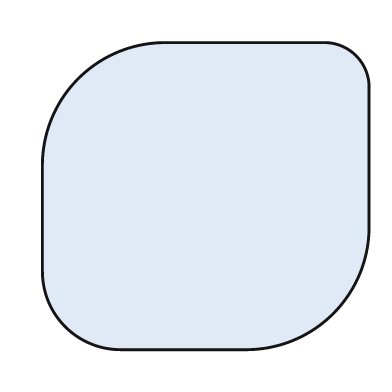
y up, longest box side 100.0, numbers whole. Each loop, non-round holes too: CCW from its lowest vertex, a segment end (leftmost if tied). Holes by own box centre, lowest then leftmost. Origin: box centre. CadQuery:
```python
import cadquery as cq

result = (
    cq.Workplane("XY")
    .moveTo(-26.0, -47.0)
    .lineTo(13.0, -47.0)
    .threePointArc((39.0, -36.0), (50.0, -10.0))
    .lineTo(50.0, 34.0)
    .threePointArc((46.0, 43.0), (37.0, 47.0))
    .lineTo(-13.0, 47.0)
    .threePointArc((-39.0, 36.0), (-50.0, 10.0))
    .lineTo(-50.0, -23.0)
    .threePointArc((-43.0, -40.0), (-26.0, -47.0))
    .close()
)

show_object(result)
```